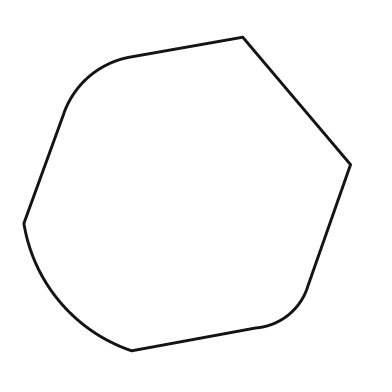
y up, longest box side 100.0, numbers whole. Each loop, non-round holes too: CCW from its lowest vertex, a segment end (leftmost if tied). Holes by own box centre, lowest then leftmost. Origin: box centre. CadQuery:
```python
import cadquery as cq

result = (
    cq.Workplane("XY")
    .moveTo(-17.0, -48.0)
    .lineTo(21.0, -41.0)
    .threePointArc((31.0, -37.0), (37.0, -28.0))
    .lineTo(50.0, 9.0)
    .lineTo(17.0, 48.0)
    .lineTo(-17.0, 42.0)
    .threePointArc((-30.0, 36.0), (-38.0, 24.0))
    .lineTo(-50.0, -9.0)
    .threePointArc((-39.0, -33.0), (-17.0, -48.0))
    .close()
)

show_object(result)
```